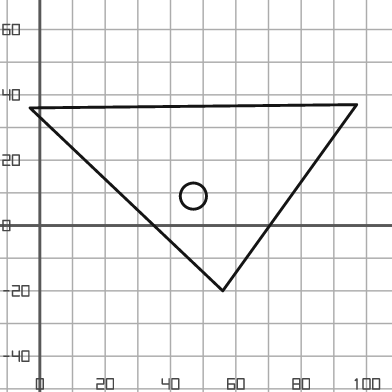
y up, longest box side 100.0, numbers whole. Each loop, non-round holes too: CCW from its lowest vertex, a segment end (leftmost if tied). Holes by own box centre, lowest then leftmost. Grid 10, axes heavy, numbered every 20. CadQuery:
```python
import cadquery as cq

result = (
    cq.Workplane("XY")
    .moveTo(56.0, -20.0)
    .lineTo(97.0, 37.0)
    .lineTo(-3.0, 36.0)
    .close()
    .moveTo(47.0, 9.0)
    .circle(4.0)
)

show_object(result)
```